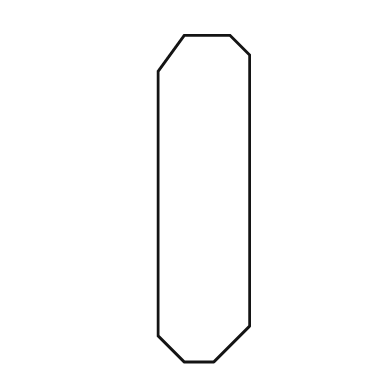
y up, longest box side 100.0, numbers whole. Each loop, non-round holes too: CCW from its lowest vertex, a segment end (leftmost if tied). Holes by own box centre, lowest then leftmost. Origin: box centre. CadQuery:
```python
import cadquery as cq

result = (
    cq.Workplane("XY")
    .moveTo(-6.0, -50.0)
    .lineTo(3.0, -50.0)
    .lineTo(14.0, -39.0)
    .lineTo(14.0, 44.0)
    .lineTo(8.0, 50.0)
    .lineTo(-6.0, 50.0)
    .lineTo(-14.0, 39.0)
    .lineTo(-14.0, -42.0)
    .close()
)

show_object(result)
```